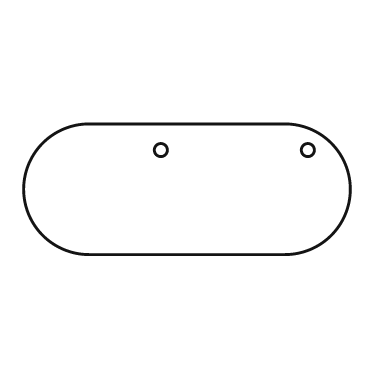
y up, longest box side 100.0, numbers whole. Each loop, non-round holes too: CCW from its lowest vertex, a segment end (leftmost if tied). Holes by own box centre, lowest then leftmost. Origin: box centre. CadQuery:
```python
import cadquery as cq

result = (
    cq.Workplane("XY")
    .moveTo(-30.0, -20.0)
    .lineTo(30.0, -20.0)
    .threePointArc((50.0, 0.0), (30.0, 20.0))
    .lineTo(-30.0, 20.0)
    .threePointArc((-50.0, 0.0), (-30.0, -20.0))
    .close()
    .moveTo(-8.0, 12.0)
    .circle(2.0)
    .moveTo(37.0, 12.0)
    .circle(2.0)
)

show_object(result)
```